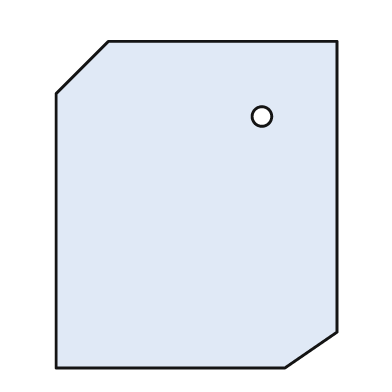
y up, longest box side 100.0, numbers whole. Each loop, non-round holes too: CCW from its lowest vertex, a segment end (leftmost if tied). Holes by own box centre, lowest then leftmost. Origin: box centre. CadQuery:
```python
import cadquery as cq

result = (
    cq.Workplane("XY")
    .moveTo(-43.0, -50.0)
    .lineTo(27.0, -50.0)
    .lineTo(43.0, -39.0)
    .lineTo(43.0, 50.0)
    .lineTo(-27.0, 50.0)
    .lineTo(-43.0, 34.0)
    .close()
    .moveTo(20.0, 27.0)
    .circle(3.0)
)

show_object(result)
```